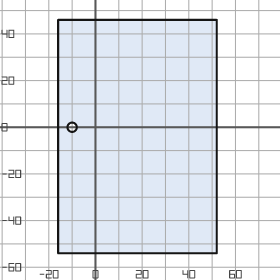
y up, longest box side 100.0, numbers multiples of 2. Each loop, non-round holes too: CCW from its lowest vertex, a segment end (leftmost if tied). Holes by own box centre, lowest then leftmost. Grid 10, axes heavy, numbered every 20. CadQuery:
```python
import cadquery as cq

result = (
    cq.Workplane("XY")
    .moveTo(-16.0, -54.0)
    .lineTo(52.0, -54.0)
    .lineTo(52.0, 46.0)
    .lineTo(-16.0, 46.0)
    .close()
    .moveTo(-10.0, 0.0)
    .circle(2.0)
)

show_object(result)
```